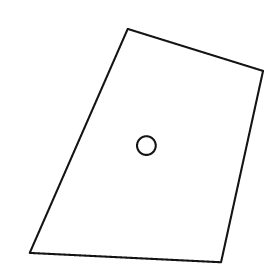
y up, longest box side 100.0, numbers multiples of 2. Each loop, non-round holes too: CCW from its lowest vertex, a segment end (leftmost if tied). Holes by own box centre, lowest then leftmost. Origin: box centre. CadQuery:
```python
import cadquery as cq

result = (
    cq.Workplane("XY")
    .moveTo(32.0, -50.0)
    .lineTo(50.0, 32.0)
    .lineTo(-8.0, 50.0)
    .lineTo(-50.0, -46.0)
    .close()
    .moveTo(0.0, 0.0)
    .circle(4.0)
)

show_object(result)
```